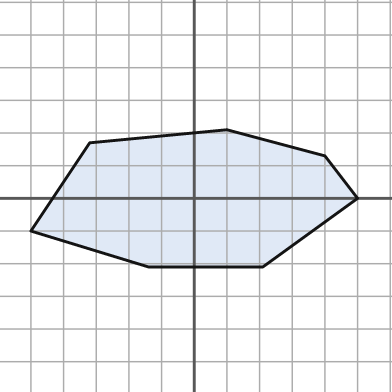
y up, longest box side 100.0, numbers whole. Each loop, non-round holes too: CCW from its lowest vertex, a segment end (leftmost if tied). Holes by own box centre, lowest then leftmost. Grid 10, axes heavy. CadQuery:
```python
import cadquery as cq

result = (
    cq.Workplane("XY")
    .moveTo(-14.0, -21.0)
    .lineTo(21.0, -21.0)
    .lineTo(50.0, 0.0)
    .lineTo(40.0, 13.0)
    .lineTo(10.0, 21.0)
    .lineTo(-32.0, 17.0)
    .lineTo(-50.0, -10.0)
    .close()
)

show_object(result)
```